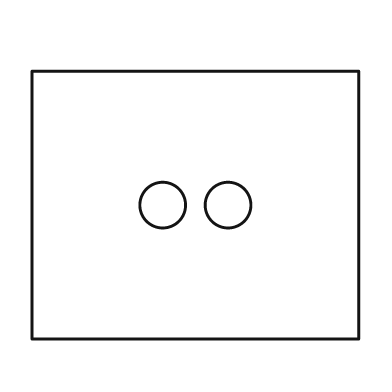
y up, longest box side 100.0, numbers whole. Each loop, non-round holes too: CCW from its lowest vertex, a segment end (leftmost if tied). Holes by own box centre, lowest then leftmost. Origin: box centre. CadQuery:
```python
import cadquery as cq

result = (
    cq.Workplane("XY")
    .moveTo(-50.0, -41.0)
    .lineTo(50.0, -41.0)
    .lineTo(50.0, 41.0)
    .lineTo(-50.0, 41.0)
    .close()
    .moveTo(-10.0, 0.0)
    .circle(7.0)
    .moveTo(10.0, 0.0)
    .circle(7.0)
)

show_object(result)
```